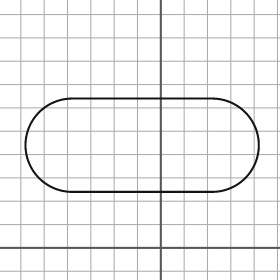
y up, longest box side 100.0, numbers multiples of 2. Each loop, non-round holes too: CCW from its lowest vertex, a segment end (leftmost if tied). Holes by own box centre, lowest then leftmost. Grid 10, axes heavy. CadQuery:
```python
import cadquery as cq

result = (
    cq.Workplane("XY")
    .moveTo(-38.0, 24.0)
    .lineTo(22.0, 24.0)
    .threePointArc((42.0, 44.0), (22.0, 64.0))
    .lineTo(-38.0, 64.0)
    .threePointArc((-58.0, 44.0), (-38.0, 24.0))
    .close()
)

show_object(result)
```